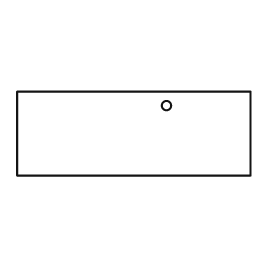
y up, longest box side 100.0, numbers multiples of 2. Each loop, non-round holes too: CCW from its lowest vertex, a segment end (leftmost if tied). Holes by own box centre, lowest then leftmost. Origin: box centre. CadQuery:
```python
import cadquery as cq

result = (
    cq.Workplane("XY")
    .moveTo(-50.0, -18.0)
    .lineTo(50.0, -18.0)
    .lineTo(50.0, 18.0)
    .lineTo(-50.0, 18.0)
    .close()
    .moveTo(14.0, 12.0)
    .circle(2.0)
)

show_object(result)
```